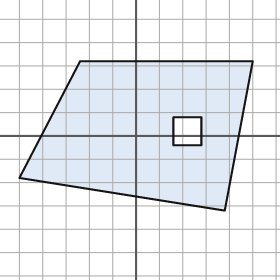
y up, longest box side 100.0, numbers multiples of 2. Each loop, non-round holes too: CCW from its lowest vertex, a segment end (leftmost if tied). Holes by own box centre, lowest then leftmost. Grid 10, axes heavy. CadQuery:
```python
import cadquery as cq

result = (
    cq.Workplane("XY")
    .moveTo(38.0, -32.0)
    .lineTo(50.0, 32.0)
    .lineTo(-24.0, 32.0)
    .lineTo(-50.0, -18.0)
    .close()
    .moveTo(16.0, -4.0)
    .lineTo(28.0, -4.0)
    .lineTo(28.0, 8.0)
    .lineTo(16.0, 8.0)
    .close()
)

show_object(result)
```